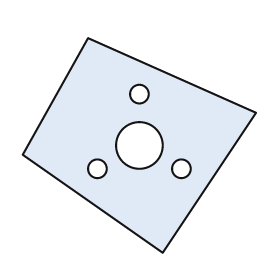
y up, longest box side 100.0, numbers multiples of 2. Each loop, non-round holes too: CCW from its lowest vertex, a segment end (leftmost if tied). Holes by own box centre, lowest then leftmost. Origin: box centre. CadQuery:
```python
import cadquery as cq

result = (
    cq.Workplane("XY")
    .moveTo(10.0, -46.0)
    .lineTo(50.0, 14.0)
    .lineTo(-22.0, 46.0)
    .lineTo(-50.0, -4.0)
    .close()
    .moveTo(-18.0, -10.0)
    .circle(4.0)
    .moveTo(18.0, -10.0)
    .circle(4.0)
    .moveTo(0.0, 0.0)
    .circle(10.0)
    .moveTo(0.0, 22.0)
    .circle(4.0)
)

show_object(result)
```